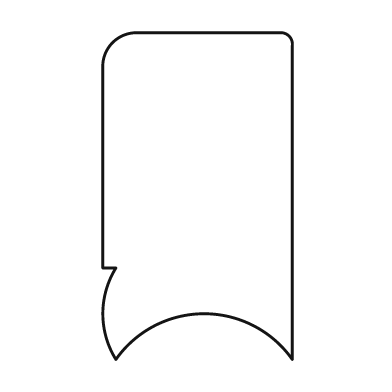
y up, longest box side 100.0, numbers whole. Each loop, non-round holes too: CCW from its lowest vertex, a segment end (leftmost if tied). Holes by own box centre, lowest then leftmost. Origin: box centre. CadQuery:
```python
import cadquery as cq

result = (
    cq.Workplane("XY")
    .moveTo(-25.0, -50.0)
    .threePointArc((2.0, -36.0), (29.0, -50.0))
    .lineTo(29.0, 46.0)
    .threePointArc((28.0, 49.0), (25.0, 50.0))
    .lineTo(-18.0, 50.0)
    .threePointArc((-26.0, 47.0), (-29.0, 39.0))
    .lineTo(-29.0, -22.0)
    .lineTo(-25.0, -22.0)
    .threePointArc((-29.0, -36.0), (-25.0, -50.0))
    .close()
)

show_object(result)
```